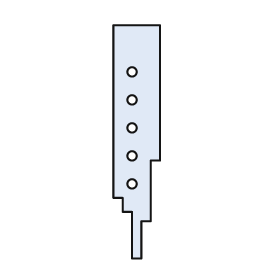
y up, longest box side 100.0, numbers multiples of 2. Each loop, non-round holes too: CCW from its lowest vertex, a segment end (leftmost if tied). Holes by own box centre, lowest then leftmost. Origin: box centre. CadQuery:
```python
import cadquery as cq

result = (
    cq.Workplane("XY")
    .moveTo(-2.0, -50.0)
    .lineTo(2.0, -50.0)
    .lineTo(2.0, -34.0)
    .lineTo(6.0, -34.0)
    .lineTo(6.0, -8.0)
    .lineTo(10.0, -8.0)
    .lineTo(10.0, 50.0)
    .lineTo(-10.0, 50.0)
    .lineTo(-10.0, -24.0)
    .lineTo(-6.0, -24.0)
    .lineTo(-6.0, -30.0)
    .lineTo(-2.0, -30.0)
    .close()
    .moveTo(-2.0, -18.0)
    .circle(2.0)
    .moveTo(-2.0, -6.0)
    .circle(2.0)
    .moveTo(-2.0, 6.0)
    .circle(2.0)
    .moveTo(-2.0, 18.0)
    .circle(2.0)
    .moveTo(-2.0, 30.0)
    .circle(2.0)
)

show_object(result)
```